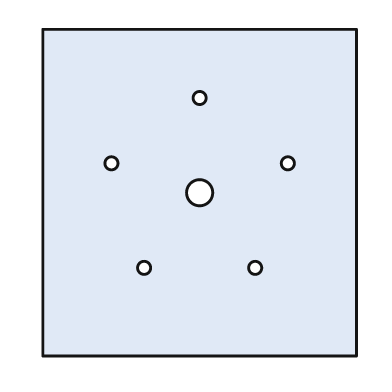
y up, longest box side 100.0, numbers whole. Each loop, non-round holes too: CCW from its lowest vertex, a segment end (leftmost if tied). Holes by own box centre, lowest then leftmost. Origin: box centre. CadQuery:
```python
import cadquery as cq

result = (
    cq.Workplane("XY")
    .moveTo(-48.0, -50.0)
    .lineTo(48.0, -50.0)
    .lineTo(48.0, 50.0)
    .lineTo(-48.0, 50.0)
    .close()
    .moveTo(-17.0, -23.0)
    .circle(2.0)
    .moveTo(17.0, -23.0)
    .circle(2.0)
    .moveTo(0.0, 0.0)
    .circle(4.0)
    .moveTo(-27.0, 9.0)
    .circle(2.0)
    .moveTo(27.0, 9.0)
    .circle(2.0)
    .moveTo(0.0, 29.0)
    .circle(2.0)
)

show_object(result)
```